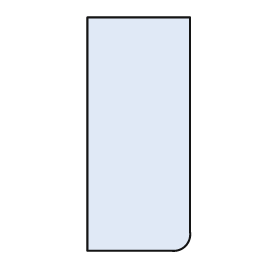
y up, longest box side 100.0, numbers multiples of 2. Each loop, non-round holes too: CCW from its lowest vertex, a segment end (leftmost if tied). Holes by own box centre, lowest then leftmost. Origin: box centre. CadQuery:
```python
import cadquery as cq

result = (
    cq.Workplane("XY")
    .moveTo(-22.0, -50.0)
    .lineTo(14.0, -50.0)
    .threePointArc((20.0, -48.0), (22.0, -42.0))
    .lineTo(22.0, 50.0)
    .lineTo(-22.0, 50.0)
    .close()
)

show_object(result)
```